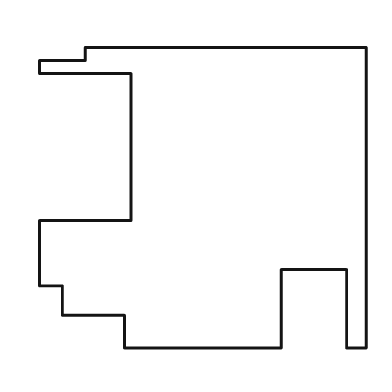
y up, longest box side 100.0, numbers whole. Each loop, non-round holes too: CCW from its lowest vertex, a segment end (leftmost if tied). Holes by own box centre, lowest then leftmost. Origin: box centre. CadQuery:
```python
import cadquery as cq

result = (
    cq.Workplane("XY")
    .moveTo(-24.0, -46.0)
    .lineTo(24.0, -46.0)
    .lineTo(24.0, -22.0)
    .lineTo(44.0, -22.0)
    .lineTo(44.0, -46.0)
    .lineTo(50.0, -46.0)
    .lineTo(50.0, 46.0)
    .lineTo(-36.0, 46.0)
    .lineTo(-36.0, 42.0)
    .lineTo(-50.0, 42.0)
    .lineTo(-50.0, 38.0)
    .lineTo(-22.0, 38.0)
    .lineTo(-22.0, -7.0)
    .lineTo(-50.0, -7.0)
    .lineTo(-50.0, -27.0)
    .lineTo(-43.0, -27.0)
    .lineTo(-43.0, -36.0)
    .lineTo(-24.0, -36.0)
    .close()
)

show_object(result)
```